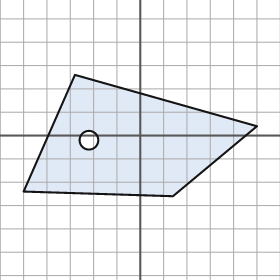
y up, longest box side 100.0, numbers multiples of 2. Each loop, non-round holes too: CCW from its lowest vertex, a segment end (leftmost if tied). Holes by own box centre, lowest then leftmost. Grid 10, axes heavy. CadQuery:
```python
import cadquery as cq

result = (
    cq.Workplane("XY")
    .moveTo(14.0, -26.0)
    .lineTo(50.0, 4.0)
    .lineTo(-28.0, 26.0)
    .lineTo(-50.0, -24.0)
    .close()
    .moveTo(-22.0, -2.0)
    .circle(4.0)
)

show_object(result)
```